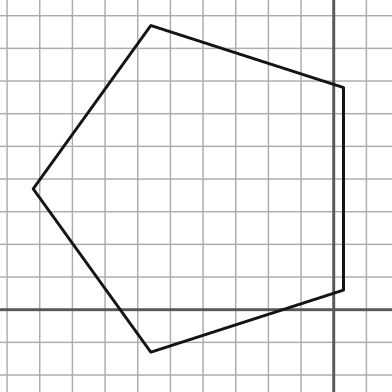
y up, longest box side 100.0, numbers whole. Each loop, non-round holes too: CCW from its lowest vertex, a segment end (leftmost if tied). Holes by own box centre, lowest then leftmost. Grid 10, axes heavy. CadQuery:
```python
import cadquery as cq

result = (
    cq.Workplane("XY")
    .moveTo(-56.0, -13.0)
    .lineTo(3.0, 6.0)
    .lineTo(3.0, 68.0)
    .lineTo(-56.0, 87.0)
    .lineTo(-92.0, 37.0)
    .close()
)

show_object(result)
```